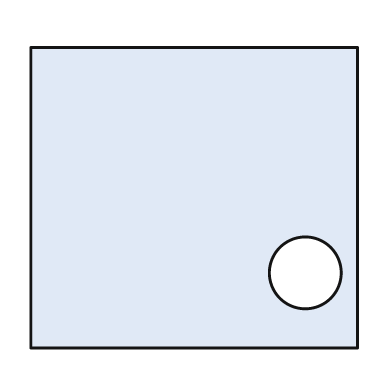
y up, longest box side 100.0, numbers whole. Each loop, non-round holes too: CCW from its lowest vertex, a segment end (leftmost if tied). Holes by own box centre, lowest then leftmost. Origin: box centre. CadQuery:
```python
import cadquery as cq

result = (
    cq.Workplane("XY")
    .moveTo(-50.0, -46.0)
    .lineTo(50.0, -46.0)
    .lineTo(50.0, 46.0)
    .lineTo(-50.0, 46.0)
    .close()
    .moveTo(34.0, -23.0)
    .circle(11.0)
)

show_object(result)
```